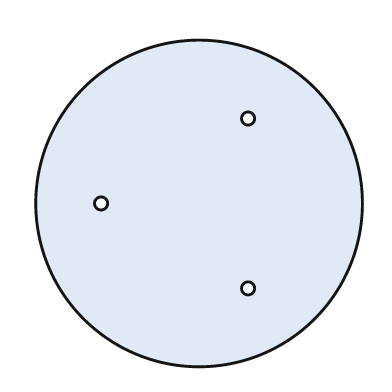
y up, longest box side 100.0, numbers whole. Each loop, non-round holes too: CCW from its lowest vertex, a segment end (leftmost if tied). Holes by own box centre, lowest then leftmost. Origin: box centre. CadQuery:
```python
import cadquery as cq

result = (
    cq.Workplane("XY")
    .moveTo(0.0, 0.0)
    .circle(50.0)
    .moveTo(15.0, -26.0)
    .circle(2.0)
    .moveTo(-30.0, 0.0)
    .circle(2.0)
    .moveTo(15.0, 26.0)
    .circle(2.0)
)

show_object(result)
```